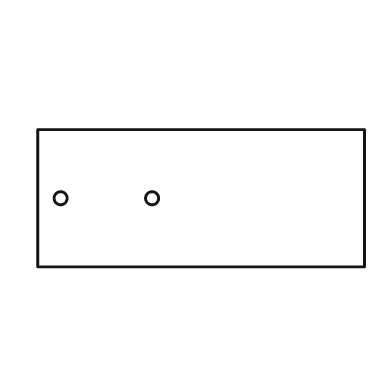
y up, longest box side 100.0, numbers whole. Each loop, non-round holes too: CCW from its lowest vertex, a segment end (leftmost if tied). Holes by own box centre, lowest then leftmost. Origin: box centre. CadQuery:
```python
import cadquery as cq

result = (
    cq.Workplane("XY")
    .moveTo(-50.0, -21.0)
    .lineTo(50.0, -21.0)
    .lineTo(50.0, 21.0)
    .lineTo(-50.0, 21.0)
    .close()
    .moveTo(-43.0, 0.0)
    .circle(2.0)
    .moveTo(-15.0, 0.0)
    .circle(2.0)
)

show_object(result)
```